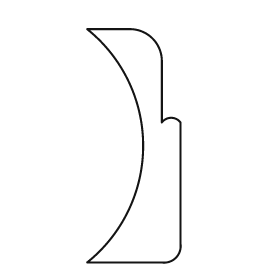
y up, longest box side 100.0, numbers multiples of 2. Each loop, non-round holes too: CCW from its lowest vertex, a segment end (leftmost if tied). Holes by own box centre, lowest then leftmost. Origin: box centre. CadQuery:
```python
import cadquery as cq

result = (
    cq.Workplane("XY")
    .moveTo(-20.0, -50.0)
    .lineTo(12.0, -50.0)
    .threePointArc((18.0, -48.0), (20.0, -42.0))
    .lineTo(20.0, 10.0)
    .threePointArc((16.0, 12.0), (12.0, 10.0))
    .lineTo(12.0, 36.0)
    .threePointArc((8.0, 46.0), (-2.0, 50.0))
    .lineTo(-20.0, 50.0)
    .threePointArc((4.0, 0.0), (-20.0, -50.0))
    .close()
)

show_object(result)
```